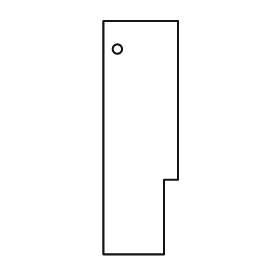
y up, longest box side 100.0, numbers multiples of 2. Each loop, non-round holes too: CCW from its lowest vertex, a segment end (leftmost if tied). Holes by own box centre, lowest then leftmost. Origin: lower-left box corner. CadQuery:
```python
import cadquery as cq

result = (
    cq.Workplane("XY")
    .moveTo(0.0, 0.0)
    .lineTo(26.0, 0.0)
    .lineTo(26.0, 32.0)
    .lineTo(32.0, 32.0)
    .lineTo(32.0, 100.0)
    .lineTo(0.0, 100.0)
    .close()
    .moveTo(6.0, 88.0)
    .circle(2.0)
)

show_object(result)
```